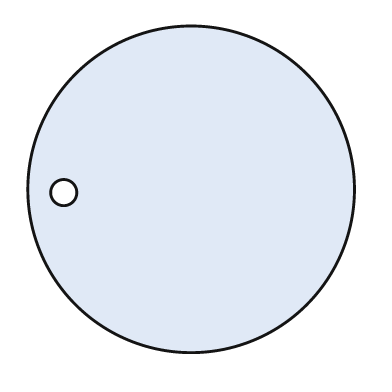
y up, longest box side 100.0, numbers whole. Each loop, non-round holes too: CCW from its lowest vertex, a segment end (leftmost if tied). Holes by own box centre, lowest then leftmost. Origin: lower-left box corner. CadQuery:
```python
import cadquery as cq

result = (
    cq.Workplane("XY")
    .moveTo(50.0, 50.0)
    .circle(50.0)
    .moveTo(11.0, 49.0)
    .circle(4.0)
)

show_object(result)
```